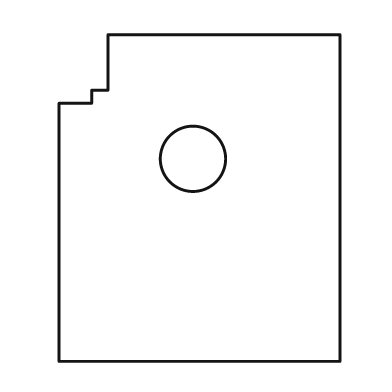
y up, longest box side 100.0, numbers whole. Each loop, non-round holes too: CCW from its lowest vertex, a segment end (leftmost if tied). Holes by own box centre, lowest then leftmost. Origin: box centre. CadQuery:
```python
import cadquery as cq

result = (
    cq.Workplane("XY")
    .moveTo(-43.0, -50.0)
    .lineTo(43.0, -50.0)
    .lineTo(43.0, 50.0)
    .lineTo(-28.0, 50.0)
    .lineTo(-28.0, 33.0)
    .lineTo(-33.0, 33.0)
    .lineTo(-33.0, 29.0)
    .lineTo(-43.0, 29.0)
    .close()
    .moveTo(-2.0, 12.0)
    .circle(10.0)
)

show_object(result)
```